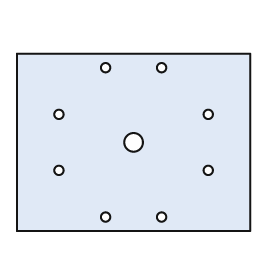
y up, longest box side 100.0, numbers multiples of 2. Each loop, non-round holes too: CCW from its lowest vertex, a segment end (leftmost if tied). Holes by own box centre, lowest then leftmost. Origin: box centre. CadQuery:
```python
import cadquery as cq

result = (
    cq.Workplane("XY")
    .moveTo(-50.0, -38.0)
    .lineTo(50.0, -38.0)
    .lineTo(50.0, 38.0)
    .lineTo(-50.0, 38.0)
    .close()
    .moveTo(-12.0, -32.0)
    .circle(2.0)
    .moveTo(12.0, -32.0)
    .circle(2.0)
    .moveTo(-32.0, -12.0)
    .circle(2.0)
    .moveTo(32.0, -12.0)
    .circle(2.0)
    .moveTo(0.0, 0.0)
    .circle(4.0)
    .moveTo(-32.0, 12.0)
    .circle(2.0)
    .moveTo(32.0, 12.0)
    .circle(2.0)
    .moveTo(-12.0, 32.0)
    .circle(2.0)
    .moveTo(12.0, 32.0)
    .circle(2.0)
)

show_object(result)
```